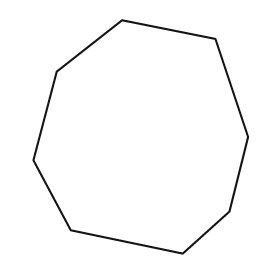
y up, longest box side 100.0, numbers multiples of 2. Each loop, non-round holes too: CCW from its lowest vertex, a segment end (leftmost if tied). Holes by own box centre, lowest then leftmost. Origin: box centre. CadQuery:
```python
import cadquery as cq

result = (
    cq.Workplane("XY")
    .moveTo(18.0, -50.0)
    .lineTo(38.0, -32.0)
    .lineTo(46.0, 0.0)
    .lineTo(32.0, 42.0)
    .lineTo(-8.0, 50.0)
    .lineTo(-36.0, 28.0)
    .lineTo(-46.0, -10.0)
    .lineTo(-30.0, -40.0)
    .close()
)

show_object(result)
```